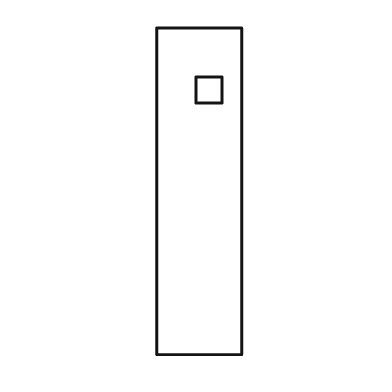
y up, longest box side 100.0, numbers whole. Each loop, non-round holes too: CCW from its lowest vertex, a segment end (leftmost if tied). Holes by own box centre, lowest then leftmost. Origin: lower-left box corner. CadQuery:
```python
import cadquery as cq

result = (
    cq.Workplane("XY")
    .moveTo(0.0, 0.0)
    .lineTo(26.0, 0.0)
    .lineTo(26.0, 100.0)
    .lineTo(0.0, 100.0)
    .close()
    .moveTo(12.0, 77.0)
    .lineTo(20.0, 77.0)
    .lineTo(20.0, 85.0)
    .lineTo(12.0, 85.0)
    .close()
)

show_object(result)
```